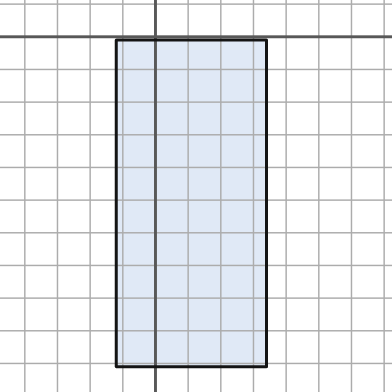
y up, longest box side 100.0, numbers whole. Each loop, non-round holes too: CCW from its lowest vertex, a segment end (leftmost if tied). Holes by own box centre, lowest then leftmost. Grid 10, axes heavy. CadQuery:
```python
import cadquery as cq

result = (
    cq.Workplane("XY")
    .moveTo(-12.0, -101.0)
    .lineTo(34.0, -101.0)
    .lineTo(34.0, -1.0)
    .lineTo(-12.0, -1.0)
    .close()
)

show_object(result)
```